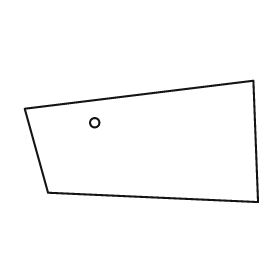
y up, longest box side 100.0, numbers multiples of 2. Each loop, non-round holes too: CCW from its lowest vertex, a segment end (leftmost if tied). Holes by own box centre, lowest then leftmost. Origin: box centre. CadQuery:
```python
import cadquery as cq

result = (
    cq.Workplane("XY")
    .moveTo(50.0, -26.0)
    .lineTo(48.0, 26.0)
    .lineTo(-50.0, 14.0)
    .lineTo(-40.0, -22.0)
    .close()
    .moveTo(-20.0, 8.0)
    .circle(2.0)
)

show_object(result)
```